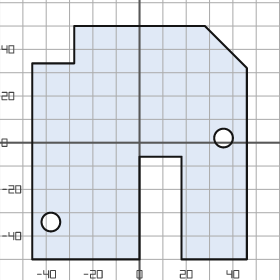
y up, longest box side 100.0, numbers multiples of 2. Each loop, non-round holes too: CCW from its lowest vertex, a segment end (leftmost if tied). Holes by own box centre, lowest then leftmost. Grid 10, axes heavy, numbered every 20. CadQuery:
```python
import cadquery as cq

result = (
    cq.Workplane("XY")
    .moveTo(-46.0, -50.0)
    .lineTo(0.0, -50.0)
    .lineTo(0.0, -6.0)
    .lineTo(18.0, -6.0)
    .lineTo(18.0, -50.0)
    .lineTo(46.0, -50.0)
    .lineTo(46.0, 32.0)
    .lineTo(28.0, 50.0)
    .lineTo(-28.0, 50.0)
    .lineTo(-28.0, 34.0)
    .lineTo(-46.0, 34.0)
    .close()
    .moveTo(-38.0, -34.0)
    .circle(4.0)
    .moveTo(36.0, 2.0)
    .circle(4.0)
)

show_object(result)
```